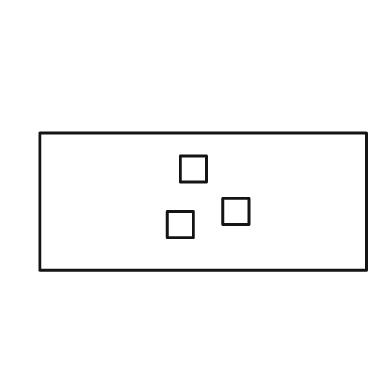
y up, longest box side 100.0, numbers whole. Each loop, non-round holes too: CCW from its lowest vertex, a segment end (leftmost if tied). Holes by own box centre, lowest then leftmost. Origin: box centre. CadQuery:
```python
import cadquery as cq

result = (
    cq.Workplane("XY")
    .moveTo(-50.0, -21.0)
    .lineTo(50.0, -21.0)
    .lineTo(50.0, 21.0)
    .lineTo(-50.0, 21.0)
    .close()
    .moveTo(-11.0, -11.0)
    .lineTo(-3.0, -11.0)
    .lineTo(-3.0, -3.0)
    .lineTo(-11.0, -3.0)
    .close()
    .moveTo(6.0, -7.0)
    .lineTo(14.0, -7.0)
    .lineTo(14.0, 1.0)
    .lineTo(6.0, 1.0)
    .close()
    .moveTo(-7.0, 6.0)
    .lineTo(1.0, 6.0)
    .lineTo(1.0, 14.0)
    .lineTo(-7.0, 14.0)
    .close()
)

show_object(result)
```